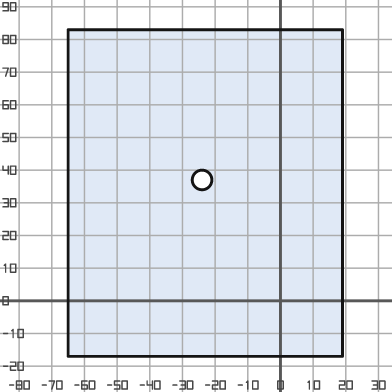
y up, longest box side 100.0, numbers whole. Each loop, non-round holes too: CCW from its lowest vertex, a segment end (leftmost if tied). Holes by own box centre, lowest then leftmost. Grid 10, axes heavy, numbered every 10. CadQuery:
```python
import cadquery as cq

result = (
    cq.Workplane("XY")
    .moveTo(-65.0, -17.0)
    .lineTo(19.0, -17.0)
    .lineTo(19.0, 83.0)
    .lineTo(-65.0, 83.0)
    .close()
    .moveTo(-24.0, 37.0)
    .circle(3.0)
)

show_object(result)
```